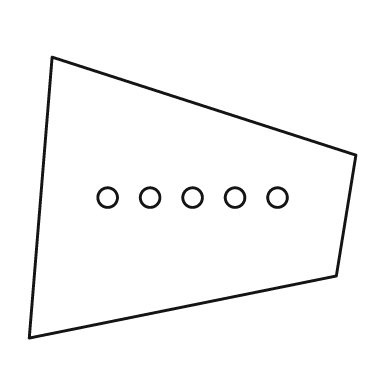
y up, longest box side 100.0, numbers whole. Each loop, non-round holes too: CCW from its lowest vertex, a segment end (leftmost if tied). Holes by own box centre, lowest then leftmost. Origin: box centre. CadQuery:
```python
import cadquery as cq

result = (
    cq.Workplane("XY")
    .moveTo(-50.0, -43.0)
    .lineTo(44.0, -24.0)
    .lineTo(50.0, 13.0)
    .lineTo(-43.0, 43.0)
    .close()
    .moveTo(-26.0, 0.0)
    .circle(3.0)
    .moveTo(-13.0, 0.0)
    .circle(3.0)
    .moveTo(0.0, 0.0)
    .circle(3.0)
    .moveTo(13.0, 0.0)
    .circle(3.0)
    .moveTo(26.0, 0.0)
    .circle(3.0)
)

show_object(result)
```